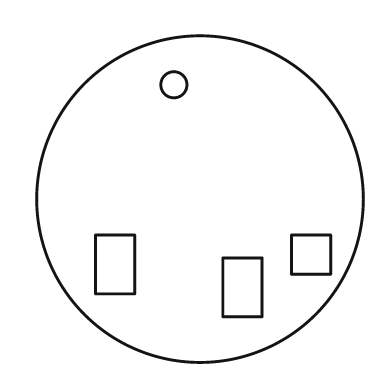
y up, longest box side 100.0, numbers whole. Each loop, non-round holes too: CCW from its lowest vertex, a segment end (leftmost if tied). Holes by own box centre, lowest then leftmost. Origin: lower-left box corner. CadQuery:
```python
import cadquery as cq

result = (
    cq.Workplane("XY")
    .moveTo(50.0, 50.0)
    .circle(50.0)
    .moveTo(57.0, 14.0)
    .lineTo(69.0, 14.0)
    .lineTo(69.0, 32.0)
    .lineTo(57.0, 32.0)
    .close()
    .moveTo(18.0, 21.0)
    .lineTo(30.0, 21.0)
    .lineTo(30.0, 39.0)
    .lineTo(18.0, 39.0)
    .close()
    .moveTo(78.0, 27.0)
    .lineTo(90.0, 27.0)
    .lineTo(90.0, 39.0)
    .lineTo(78.0, 39.0)
    .close()
    .moveTo(42.0, 85.0)
    .circle(4.0)
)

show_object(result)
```